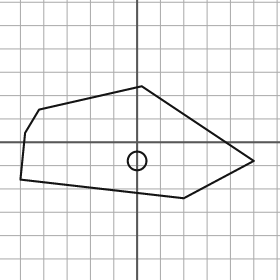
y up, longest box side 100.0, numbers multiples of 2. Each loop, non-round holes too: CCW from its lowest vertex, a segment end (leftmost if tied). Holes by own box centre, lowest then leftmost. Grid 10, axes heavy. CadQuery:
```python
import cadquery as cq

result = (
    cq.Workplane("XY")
    .moveTo(20.0, -24.0)
    .lineTo(50.0, -8.0)
    .lineTo(2.0, 24.0)
    .lineTo(-42.0, 14.0)
    .lineTo(-48.0, 4.0)
    .lineTo(-50.0, -16.0)
    .close()
    .moveTo(0.0, -8.0)
    .circle(4.0)
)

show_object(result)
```